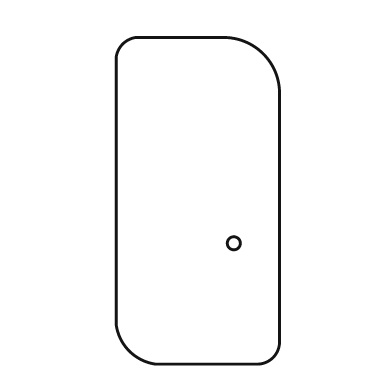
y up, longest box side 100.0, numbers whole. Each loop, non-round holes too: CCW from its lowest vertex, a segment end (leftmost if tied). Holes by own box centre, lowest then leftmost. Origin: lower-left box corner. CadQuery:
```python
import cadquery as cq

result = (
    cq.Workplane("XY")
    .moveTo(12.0, 0.0)
    .lineTo(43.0, 0.0)
    .threePointArc((48.0, 2.0), (50.0, 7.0))
    .lineTo(50.0, 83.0)
    .threePointArc((45.0, 95.0), (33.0, 100.0))
    .lineTo(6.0, 100.0)
    .threePointArc((2.0, 98.0), (0.0, 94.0))
    .lineTo(0.0, 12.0)
    .threePointArc((4.0, 4.0), (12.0, 0.0))
    .close()
    .moveTo(36.0, 37.0)
    .circle(2.0)
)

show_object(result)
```